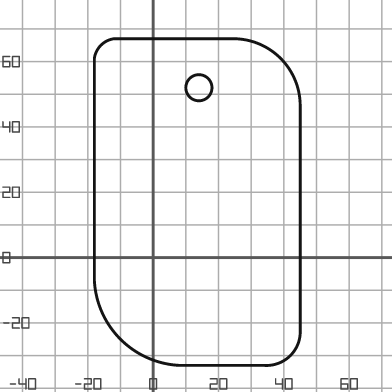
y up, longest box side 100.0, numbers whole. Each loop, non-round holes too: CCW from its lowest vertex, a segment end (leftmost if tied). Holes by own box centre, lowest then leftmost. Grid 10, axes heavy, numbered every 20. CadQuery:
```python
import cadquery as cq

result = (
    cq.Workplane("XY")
    .moveTo(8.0, -33.0)
    .lineTo(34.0, -33.0)
    .threePointArc((42.0, -30.0), (45.0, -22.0))
    .lineTo(45.0, 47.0)
    .threePointArc((39.0, 61.0), (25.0, 67.0))
    .lineTo(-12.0, 67.0)
    .threePointArc((-16.0, 65.0), (-18.0, 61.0))
    .lineTo(-18.0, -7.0)
    .threePointArc((-10.0, -25.0), (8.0, -33.0))
    .close()
    .moveTo(14.0, 52.0)
    .circle(4.0)
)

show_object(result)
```